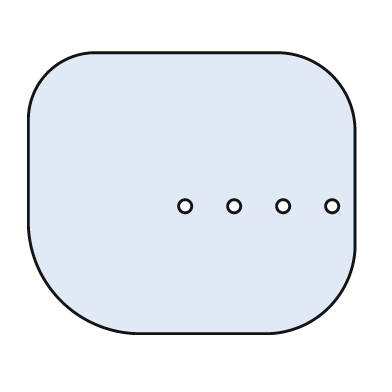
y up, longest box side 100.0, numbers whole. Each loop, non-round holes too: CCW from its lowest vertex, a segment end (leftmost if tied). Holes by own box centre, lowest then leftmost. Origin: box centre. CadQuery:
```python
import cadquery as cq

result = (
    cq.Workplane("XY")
    .moveTo(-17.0, -43.0)
    .lineTo(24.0, -43.0)
    .threePointArc((42.0, -35.0), (50.0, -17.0))
    .lineTo(50.0, 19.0)
    .threePointArc((43.0, 36.0), (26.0, 43.0))
    .lineTo(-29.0, 43.0)
    .threePointArc((-44.0, 37.0), (-50.0, 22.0))
    .lineTo(-50.0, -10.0)
    .threePointArc((-40.0, -33.0), (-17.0, -43.0))
    .close()
    .moveTo(-2.0, -4.0)
    .circle(2.0)
    .moveTo(13.0, -4.0)
    .circle(2.0)
    .moveTo(28.0, -4.0)
    .circle(2.0)
    .moveTo(43.0, -4.0)
    .circle(2.0)
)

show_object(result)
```